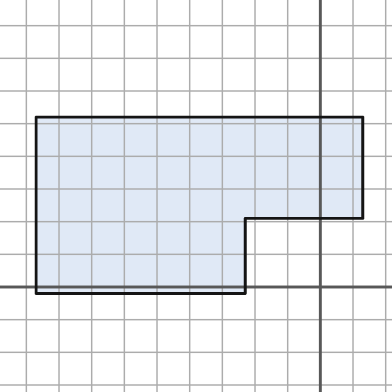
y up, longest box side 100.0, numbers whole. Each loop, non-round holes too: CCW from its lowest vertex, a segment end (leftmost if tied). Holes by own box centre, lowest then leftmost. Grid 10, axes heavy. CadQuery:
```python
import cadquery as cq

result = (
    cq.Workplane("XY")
    .moveTo(-87.0, -2.0)
    .lineTo(-23.0, -2.0)
    .lineTo(-23.0, 21.0)
    .lineTo(13.0, 21.0)
    .lineTo(13.0, 52.0)
    .lineTo(-87.0, 52.0)
    .close()
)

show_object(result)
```